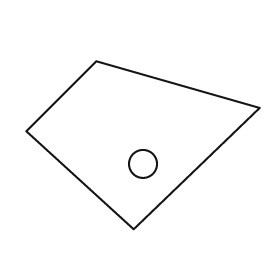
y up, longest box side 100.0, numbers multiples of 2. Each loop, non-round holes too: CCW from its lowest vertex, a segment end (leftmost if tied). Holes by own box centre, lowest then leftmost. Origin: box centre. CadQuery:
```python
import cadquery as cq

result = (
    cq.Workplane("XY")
    .moveTo(-4.0, -36.0)
    .lineTo(50.0, 16.0)
    .lineTo(-20.0, 36.0)
    .lineTo(-50.0, 6.0)
    .close()
    .moveTo(0.0, -8.0)
    .circle(6.0)
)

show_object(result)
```